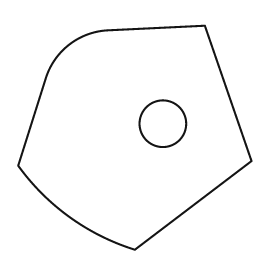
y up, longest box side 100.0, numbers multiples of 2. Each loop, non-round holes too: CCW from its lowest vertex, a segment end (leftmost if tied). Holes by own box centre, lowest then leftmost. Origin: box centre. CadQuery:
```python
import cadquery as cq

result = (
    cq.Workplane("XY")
    .moveTo(0.0, -48.0)
    .lineTo(50.0, -10.0)
    .lineTo(30.0, 48.0)
    .lineTo(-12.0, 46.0)
    .threePointArc((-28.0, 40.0), (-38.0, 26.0))
    .lineTo(-50.0, -12.0)
    .threePointArc((-28.0, -34.0), (0.0, -48.0))
    .close()
    .moveTo(12.0, 6.0)
    .circle(10.0)
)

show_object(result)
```